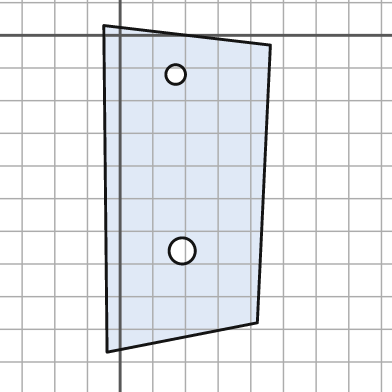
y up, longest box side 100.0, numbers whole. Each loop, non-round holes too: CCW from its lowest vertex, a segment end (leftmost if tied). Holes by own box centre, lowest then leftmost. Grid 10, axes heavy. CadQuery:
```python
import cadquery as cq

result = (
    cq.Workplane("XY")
    .moveTo(-4.0, -97.0)
    .lineTo(42.0, -88.0)
    .lineTo(46.0, -3.0)
    .lineTo(-5.0, 3.0)
    .close()
    .moveTo(19.0, -66.0)
    .circle(4.0)
    .moveTo(17.0, -12.0)
    .circle(3.0)
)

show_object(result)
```